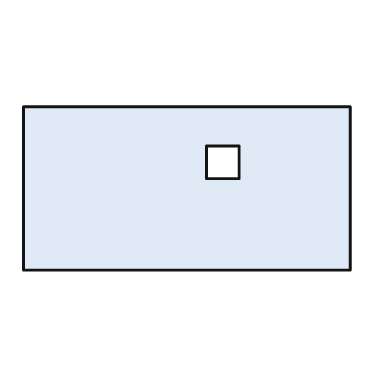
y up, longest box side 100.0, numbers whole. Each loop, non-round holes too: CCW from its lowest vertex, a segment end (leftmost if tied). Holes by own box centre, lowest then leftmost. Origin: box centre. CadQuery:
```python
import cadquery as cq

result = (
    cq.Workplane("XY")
    .moveTo(-50.0, -25.0)
    .lineTo(50.0, -25.0)
    .lineTo(50.0, 25.0)
    .lineTo(-50.0, 25.0)
    .close()
    .moveTo(6.0, 3.0)
    .lineTo(16.0, 3.0)
    .lineTo(16.0, 13.0)
    .lineTo(6.0, 13.0)
    .close()
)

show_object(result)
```